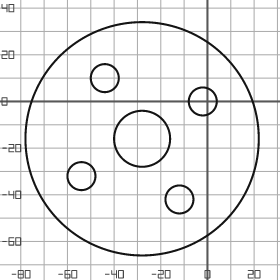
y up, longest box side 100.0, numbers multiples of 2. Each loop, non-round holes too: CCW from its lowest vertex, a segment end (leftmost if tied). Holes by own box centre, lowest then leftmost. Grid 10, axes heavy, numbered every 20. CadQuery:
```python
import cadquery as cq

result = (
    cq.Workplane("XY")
    .moveTo(-28.0, -16.0)
    .circle(50.0)
    .moveTo(-12.0, -42.0)
    .circle(6.0)
    .moveTo(-54.0, -32.0)
    .circle(6.0)
    .moveTo(-28.0, -16.0)
    .circle(12.0)
    .moveTo(-2.0, 0.0)
    .circle(6.0)
    .moveTo(-44.0, 10.0)
    .circle(6.0)
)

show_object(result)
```